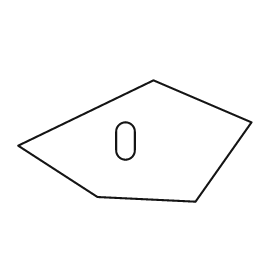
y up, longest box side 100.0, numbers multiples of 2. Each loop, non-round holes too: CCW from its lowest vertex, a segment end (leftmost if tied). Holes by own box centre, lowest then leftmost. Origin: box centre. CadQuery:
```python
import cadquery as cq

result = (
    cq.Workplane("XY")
    .moveTo(26.0, -26.0)
    .lineTo(50.0, 8.0)
    .lineTo(8.0, 26.0)
    .lineTo(-50.0, -2.0)
    .lineTo(-16.0, -24.0)
    .close()
    .moveTo(-8.0, -4.0)
    .threePointArc((-4.0, -8.0), (0.0, -4.0))
    .lineTo(0.0, 4.0)
    .threePointArc((-4.0, 8.0), (-8.0, 4.0))
    .close()
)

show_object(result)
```